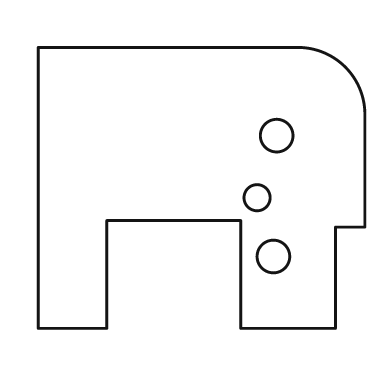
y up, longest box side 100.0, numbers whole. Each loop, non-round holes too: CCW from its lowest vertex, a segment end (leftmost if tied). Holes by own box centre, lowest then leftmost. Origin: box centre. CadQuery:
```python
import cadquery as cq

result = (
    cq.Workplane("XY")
    .moveTo(-50.0, -43.0)
    .lineTo(-29.0, -43.0)
    .lineTo(-29.0, -10.0)
    .lineTo(12.0, -10.0)
    .lineTo(12.0, -43.0)
    .lineTo(41.0, -43.0)
    .lineTo(41.0, -12.0)
    .lineTo(50.0, -12.0)
    .lineTo(50.0, 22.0)
    .threePointArc((44.0, 37.0), (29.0, 43.0))
    .lineTo(-50.0, 43.0)
    .close()
    .moveTo(22.0, -21.0)
    .circle(5.0)
    .moveTo(17.0, -3.0)
    .circle(4.0)
    .moveTo(23.0, 16.0)
    .circle(5.0)
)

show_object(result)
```